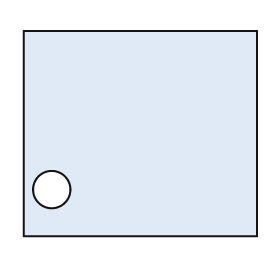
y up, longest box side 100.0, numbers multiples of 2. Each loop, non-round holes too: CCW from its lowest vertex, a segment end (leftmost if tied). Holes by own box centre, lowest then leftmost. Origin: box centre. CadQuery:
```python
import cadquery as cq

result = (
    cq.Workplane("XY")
    .moveTo(-50.0, -44.0)
    .lineTo(50.0, -44.0)
    .lineTo(50.0, 44.0)
    .lineTo(-50.0, 44.0)
    .close()
    .moveTo(-38.0, -24.0)
    .circle(8.0)
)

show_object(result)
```